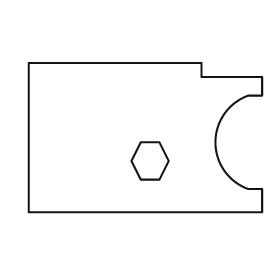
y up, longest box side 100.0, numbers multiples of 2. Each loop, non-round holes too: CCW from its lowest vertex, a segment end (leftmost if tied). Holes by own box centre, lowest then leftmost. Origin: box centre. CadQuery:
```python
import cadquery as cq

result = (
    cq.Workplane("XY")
    .moveTo(-50.0, -32.0)
    .lineTo(50.0, -32.0)
    .lineTo(50.0, -22.0)
    .lineTo(44.0, -22.0)
    .threePointArc((30.0, -2.0), (44.0, 18.0))
    .lineTo(50.0, 18.0)
    .lineTo(50.0, 26.0)
    .lineTo(24.0, 26.0)
    .lineTo(24.0, 32.0)
    .lineTo(-50.0, 32.0)
    .close()
    .moveTo(-2.0, -18.0)
    .lineTo(6.0, -18.0)
    .lineTo(10.0, -10.0)
    .lineTo(6.0, -2.0)
    .lineTo(-2.0, -2.0)
    .lineTo(-6.0, -10.0)
    .close()
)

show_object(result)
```